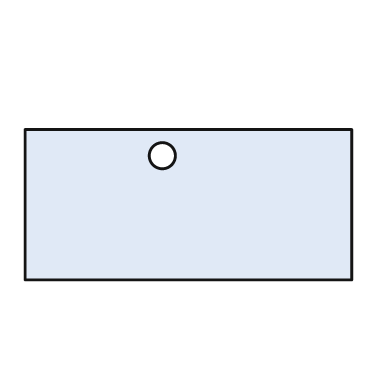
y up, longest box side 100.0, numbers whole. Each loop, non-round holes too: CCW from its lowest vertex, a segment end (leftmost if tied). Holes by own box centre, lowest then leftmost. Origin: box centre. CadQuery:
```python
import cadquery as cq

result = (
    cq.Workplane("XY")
    .moveTo(-50.0, -23.0)
    .lineTo(50.0, -23.0)
    .lineTo(50.0, 23.0)
    .lineTo(-50.0, 23.0)
    .close()
    .moveTo(-8.0, 15.0)
    .circle(4.0)
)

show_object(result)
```